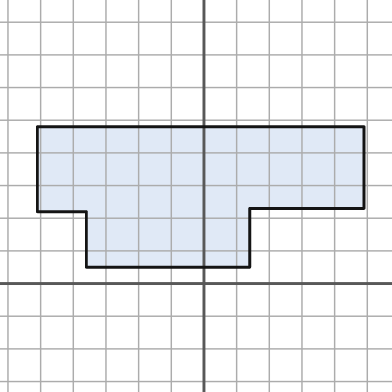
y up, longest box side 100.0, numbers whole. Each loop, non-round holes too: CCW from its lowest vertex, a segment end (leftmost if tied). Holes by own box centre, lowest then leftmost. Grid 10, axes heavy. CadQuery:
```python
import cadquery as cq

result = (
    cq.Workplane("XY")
    .moveTo(-36.0, 5.0)
    .lineTo(14.0, 5.0)
    .lineTo(14.0, 23.0)
    .lineTo(49.0, 23.0)
    .lineTo(49.0, 48.0)
    .lineTo(-51.0, 48.0)
    .lineTo(-51.0, 22.0)
    .lineTo(-36.0, 22.0)
    .close()
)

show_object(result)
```